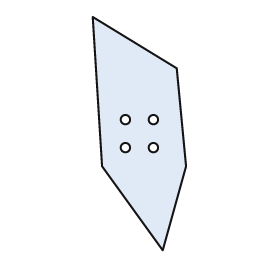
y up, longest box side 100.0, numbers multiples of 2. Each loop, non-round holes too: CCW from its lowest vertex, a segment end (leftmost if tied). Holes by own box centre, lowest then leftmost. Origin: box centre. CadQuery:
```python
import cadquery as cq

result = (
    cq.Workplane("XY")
    .moveTo(10.0, -50.0)
    .lineTo(20.0, -14.0)
    .lineTo(16.0, 28.0)
    .lineTo(-20.0, 50.0)
    .lineTo(-16.0, -14.0)
    .close()
    .moveTo(-6.0, -6.0)
    .circle(2.0)
    .moveTo(6.0, -6.0)
    .circle(2.0)
    .moveTo(-6.0, 6.0)
    .circle(2.0)
    .moveTo(6.0, 6.0)
    .circle(2.0)
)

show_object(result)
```